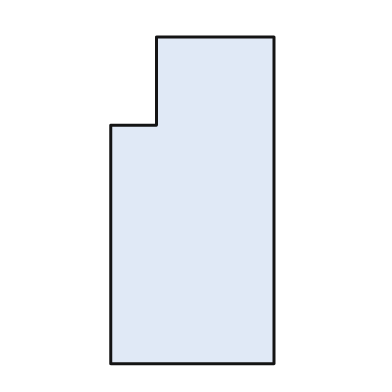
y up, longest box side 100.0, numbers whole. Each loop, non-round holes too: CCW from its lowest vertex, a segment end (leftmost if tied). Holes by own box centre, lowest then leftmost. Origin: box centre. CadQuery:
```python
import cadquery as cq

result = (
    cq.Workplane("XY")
    .moveTo(-25.0, -50.0)
    .lineTo(25.0, -50.0)
    .lineTo(25.0, 50.0)
    .lineTo(-11.0, 50.0)
    .lineTo(-11.0, 23.0)
    .lineTo(-25.0, 23.0)
    .close()
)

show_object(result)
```